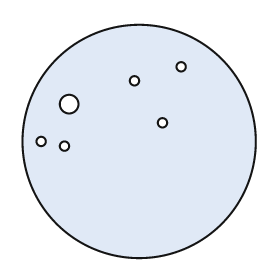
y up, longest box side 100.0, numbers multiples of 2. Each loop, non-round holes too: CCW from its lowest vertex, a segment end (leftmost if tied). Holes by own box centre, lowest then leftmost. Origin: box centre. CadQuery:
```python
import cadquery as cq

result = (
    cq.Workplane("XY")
    .moveTo(0.0, 0.0)
    .circle(50.0)
    .moveTo(-32.0, -2.0)
    .circle(2.0)
    .moveTo(-42.0, 0.0)
    .circle(2.0)
    .moveTo(10.0, 8.0)
    .circle(2.0)
    .moveTo(-30.0, 16.0)
    .circle(4.0)
    .moveTo(-2.0, 26.0)
    .circle(2.0)
    .moveTo(18.0, 32.0)
    .circle(2.0)
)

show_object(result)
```